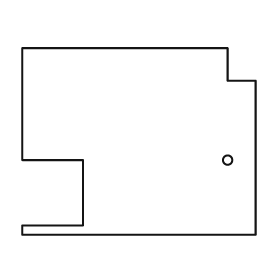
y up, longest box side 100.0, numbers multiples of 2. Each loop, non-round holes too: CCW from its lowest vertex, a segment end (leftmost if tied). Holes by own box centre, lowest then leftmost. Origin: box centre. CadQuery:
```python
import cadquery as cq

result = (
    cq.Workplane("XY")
    .moveTo(-50.0, -40.0)
    .lineTo(50.0, -40.0)
    .lineTo(50.0, 26.0)
    .lineTo(38.0, 26.0)
    .lineTo(38.0, 40.0)
    .lineTo(-50.0, 40.0)
    .lineTo(-50.0, -8.0)
    .lineTo(-24.0, -8.0)
    .lineTo(-24.0, -36.0)
    .lineTo(-50.0, -36.0)
    .close()
    .moveTo(38.0, -8.0)
    .circle(2.0)
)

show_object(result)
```